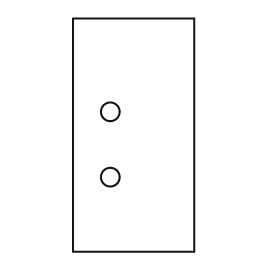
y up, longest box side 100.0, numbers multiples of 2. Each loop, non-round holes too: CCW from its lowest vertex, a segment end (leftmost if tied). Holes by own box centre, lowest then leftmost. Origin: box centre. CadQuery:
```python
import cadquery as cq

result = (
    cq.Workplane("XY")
    .moveTo(-26.0, -50.0)
    .lineTo(26.0, -50.0)
    .lineTo(26.0, 50.0)
    .lineTo(-26.0, 50.0)
    .close()
    .moveTo(-10.0, -18.0)
    .circle(4.0)
    .moveTo(-10.0, 10.0)
    .circle(4.0)
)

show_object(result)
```